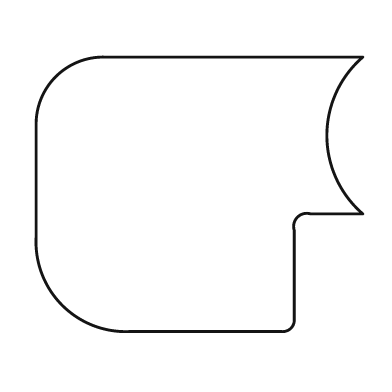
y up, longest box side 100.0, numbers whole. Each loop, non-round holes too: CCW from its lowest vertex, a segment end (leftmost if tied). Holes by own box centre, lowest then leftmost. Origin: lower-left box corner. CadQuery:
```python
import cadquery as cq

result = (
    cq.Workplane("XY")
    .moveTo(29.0, 0.0)
    .lineTo(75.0, 0.0)
    .threePointArc((78.0, 1.0), (79.0, 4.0))
    .lineTo(79.0, 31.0)
    .threePointArc((80.0, 35.0), (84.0, 36.0))
    .lineTo(100.0, 36.0)
    .threePointArc((89.0, 60.0), (100.0, 84.0))
    .lineTo(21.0, 84.0)
    .threePointArc((6.0, 78.0), (0.0, 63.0))
    .lineTo(0.0, 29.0)
    .threePointArc((8.0, 8.0), (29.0, 0.0))
    .close()
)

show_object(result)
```